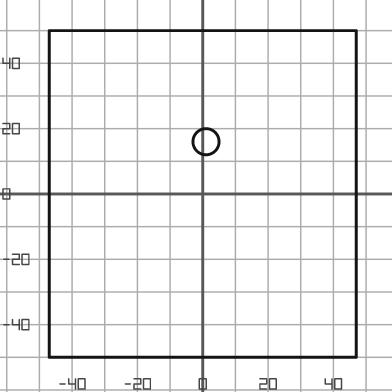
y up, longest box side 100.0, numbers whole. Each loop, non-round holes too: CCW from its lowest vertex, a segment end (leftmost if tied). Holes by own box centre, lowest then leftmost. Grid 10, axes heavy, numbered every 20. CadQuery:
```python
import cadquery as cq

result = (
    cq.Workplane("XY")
    .moveTo(-47.0, -50.0)
    .lineTo(47.0, -50.0)
    .lineTo(47.0, 50.0)
    .lineTo(-47.0, 50.0)
    .close()
    .moveTo(1.0, 16.0)
    .circle(4.0)
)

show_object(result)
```